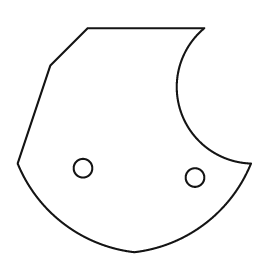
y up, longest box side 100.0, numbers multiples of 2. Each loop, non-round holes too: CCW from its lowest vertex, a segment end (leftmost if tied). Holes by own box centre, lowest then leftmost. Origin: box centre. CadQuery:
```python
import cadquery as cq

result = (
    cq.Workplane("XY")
    .moveTo(0.0, -48.0)
    .threePointArc((30.0, -36.0), (50.0, -10.0))
    .threePointArc((20.0, 12.0), (30.0, 48.0))
    .lineTo(-20.0, 48.0)
    .lineTo(-36.0, 32.0)
    .lineTo(-50.0, -10.0)
    .threePointArc((-30.0, -36.0), (0.0, -48.0))
    .close()
    .moveTo(26.0, -16.0)
    .circle(4.0)
    .moveTo(-22.0, -12.0)
    .circle(4.0)
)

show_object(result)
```